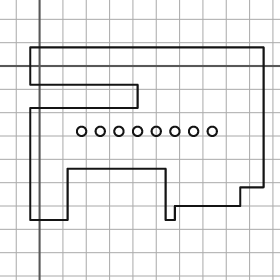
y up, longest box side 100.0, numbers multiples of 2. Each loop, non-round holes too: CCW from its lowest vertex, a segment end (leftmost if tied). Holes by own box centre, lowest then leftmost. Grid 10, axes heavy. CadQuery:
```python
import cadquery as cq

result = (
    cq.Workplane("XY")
    .moveTo(-4.0, -66.0)
    .lineTo(12.0, -66.0)
    .lineTo(12.0, -44.0)
    .lineTo(54.0, -44.0)
    .lineTo(54.0, -66.0)
    .lineTo(58.0, -66.0)
    .lineTo(58.0, -60.0)
    .lineTo(86.0, -60.0)
    .lineTo(86.0, -52.0)
    .lineTo(96.0, -52.0)
    .lineTo(96.0, 8.0)
    .lineTo(-4.0, 8.0)
    .lineTo(-4.0, -8.0)
    .lineTo(42.0, -8.0)
    .lineTo(42.0, -18.0)
    .lineTo(-4.0, -18.0)
    .close()
    .moveTo(18.0, -28.0)
    .circle(2.0)
    .moveTo(26.0, -28.0)
    .circle(2.0)
    .moveTo(34.0, -28.0)
    .circle(2.0)
    .moveTo(42.0, -28.0)
    .circle(2.0)
    .moveTo(50.0, -28.0)
    .circle(2.0)
    .moveTo(58.0, -28.0)
    .circle(2.0)
    .moveTo(66.0, -28.0)
    .circle(2.0)
    .moveTo(74.0, -28.0)
    .circle(2.0)
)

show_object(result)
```